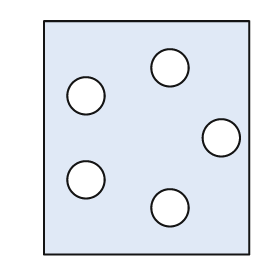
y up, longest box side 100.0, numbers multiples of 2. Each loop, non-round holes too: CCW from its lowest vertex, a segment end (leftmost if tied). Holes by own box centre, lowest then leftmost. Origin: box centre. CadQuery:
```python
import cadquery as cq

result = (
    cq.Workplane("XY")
    .moveTo(-44.0, -50.0)
    .lineTo(44.0, -50.0)
    .lineTo(44.0, 50.0)
    .lineTo(-44.0, 50.0)
    .close()
    .moveTo(10.0, -30.0)
    .circle(8.0)
    .moveTo(-26.0, -18.0)
    .circle(8.0)
    .moveTo(32.0, 0.0)
    .circle(8.0)
    .moveTo(-26.0, 18.0)
    .circle(8.0)
    .moveTo(10.0, 30.0)
    .circle(8.0)
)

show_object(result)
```